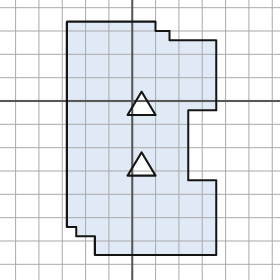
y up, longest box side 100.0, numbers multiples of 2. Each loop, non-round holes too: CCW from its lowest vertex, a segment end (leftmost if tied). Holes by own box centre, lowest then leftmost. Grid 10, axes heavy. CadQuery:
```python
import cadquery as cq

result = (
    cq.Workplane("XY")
    .moveTo(-16.0, -66.0)
    .lineTo(36.0, -66.0)
    .lineTo(36.0, -34.0)
    .lineTo(24.0, -34.0)
    .lineTo(24.0, -4.0)
    .lineTo(36.0, -4.0)
    .lineTo(36.0, 26.0)
    .lineTo(16.0, 26.0)
    .lineTo(16.0, 30.0)
    .lineTo(10.0, 30.0)
    .lineTo(10.0, 34.0)
    .lineTo(-28.0, 34.0)
    .lineTo(-28.0, -54.0)
    .lineTo(-24.0, -54.0)
    .lineTo(-24.0, -58.0)
    .lineTo(-16.0, -58.0)
    .close()
    .moveTo(-2.0, -32.0)
    .lineTo(10.0, -32.0)
    .lineTo(4.0, -22.0)
    .close()
    .moveTo(-2.0, -6.0)
    .lineTo(10.0, -6.0)
    .lineTo(4.0, 4.0)
    .close()
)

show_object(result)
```